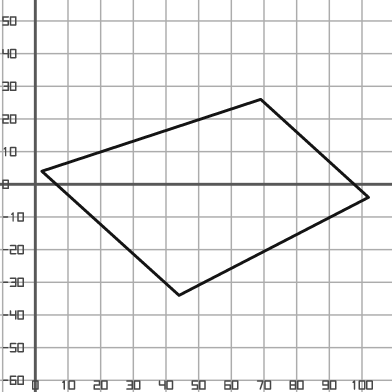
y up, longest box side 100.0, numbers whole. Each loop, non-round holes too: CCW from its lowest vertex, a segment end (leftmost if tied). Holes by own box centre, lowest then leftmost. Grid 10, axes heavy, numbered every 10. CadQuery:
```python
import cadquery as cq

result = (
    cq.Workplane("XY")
    .moveTo(44.0, -34.0)
    .lineTo(102.0, -4.0)
    .lineTo(69.0, 26.0)
    .lineTo(2.0, 4.0)
    .close()
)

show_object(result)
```